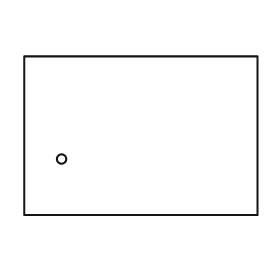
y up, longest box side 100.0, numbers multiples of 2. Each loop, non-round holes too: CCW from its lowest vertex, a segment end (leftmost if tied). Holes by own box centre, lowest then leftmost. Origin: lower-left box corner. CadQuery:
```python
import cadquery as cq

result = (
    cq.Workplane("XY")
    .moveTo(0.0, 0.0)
    .lineTo(100.0, 0.0)
    .lineTo(100.0, 68.0)
    .lineTo(0.0, 68.0)
    .close()
    .moveTo(16.0, 24.0)
    .circle(2.0)
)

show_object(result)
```